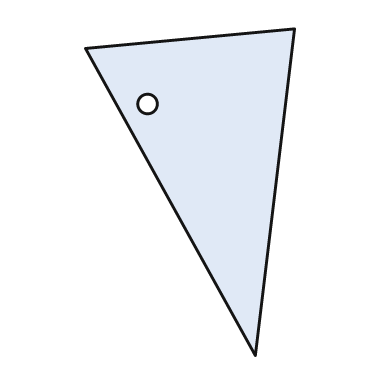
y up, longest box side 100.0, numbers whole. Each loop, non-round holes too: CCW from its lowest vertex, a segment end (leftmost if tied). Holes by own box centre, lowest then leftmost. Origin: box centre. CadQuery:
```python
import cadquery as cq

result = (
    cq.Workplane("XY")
    .moveTo(20.0, -50.0)
    .lineTo(32.0, 50.0)
    .lineTo(-32.0, 44.0)
    .close()
    .moveTo(-13.0, 27.0)
    .circle(3.0)
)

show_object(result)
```